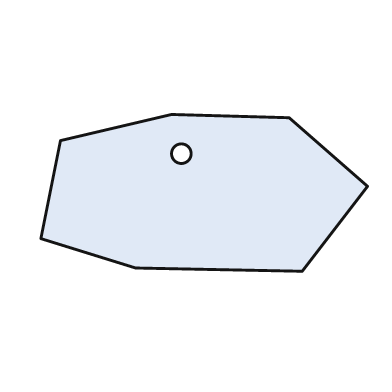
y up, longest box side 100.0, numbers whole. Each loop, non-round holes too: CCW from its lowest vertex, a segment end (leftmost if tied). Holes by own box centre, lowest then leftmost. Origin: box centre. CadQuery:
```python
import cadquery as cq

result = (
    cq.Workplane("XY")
    .moveTo(30.0, -24.0)
    .lineTo(50.0, 2.0)
    .lineTo(26.0, 23.0)
    .lineTo(-10.0, 24.0)
    .lineTo(-44.0, 16.0)
    .lineTo(-50.0, -14.0)
    .lineTo(-21.0, -23.0)
    .close()
    .moveTo(-7.0, 12.0)
    .circle(3.0)
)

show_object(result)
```